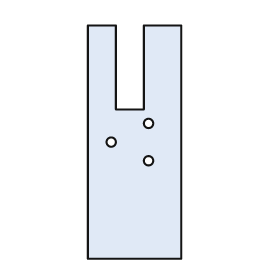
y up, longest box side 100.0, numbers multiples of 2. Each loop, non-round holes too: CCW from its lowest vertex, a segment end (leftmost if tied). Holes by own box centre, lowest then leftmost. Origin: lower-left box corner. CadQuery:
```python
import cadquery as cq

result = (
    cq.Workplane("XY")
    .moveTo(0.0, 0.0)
    .lineTo(40.0, 0.0)
    .lineTo(40.0, 100.0)
    .lineTo(24.0, 100.0)
    .lineTo(24.0, 64.0)
    .lineTo(12.0, 64.0)
    .lineTo(12.0, 100.0)
    .lineTo(0.0, 100.0)
    .close()
    .moveTo(26.0, 42.0)
    .circle(2.0)
    .moveTo(10.0, 50.0)
    .circle(2.0)
    .moveTo(26.0, 58.0)
    .circle(2.0)
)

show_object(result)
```